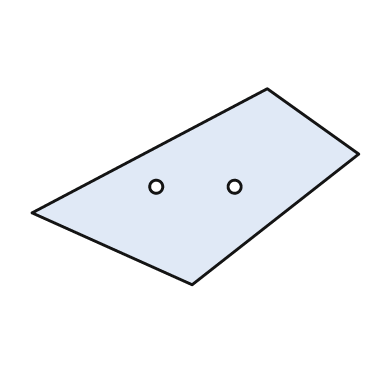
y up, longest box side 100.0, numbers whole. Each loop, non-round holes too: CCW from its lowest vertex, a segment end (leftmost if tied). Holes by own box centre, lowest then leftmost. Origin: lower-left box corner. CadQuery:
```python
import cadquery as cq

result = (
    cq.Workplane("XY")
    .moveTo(49.0, 0.0)
    .lineTo(100.0, 40.0)
    .lineTo(72.0, 60.0)
    .lineTo(0.0, 22.0)
    .close()
    .moveTo(38.0, 30.0)
    .circle(2.0)
    .moveTo(62.0, 30.0)
    .circle(2.0)
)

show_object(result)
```